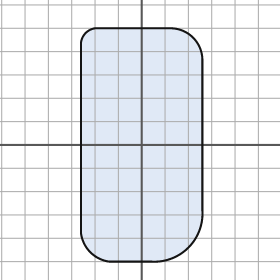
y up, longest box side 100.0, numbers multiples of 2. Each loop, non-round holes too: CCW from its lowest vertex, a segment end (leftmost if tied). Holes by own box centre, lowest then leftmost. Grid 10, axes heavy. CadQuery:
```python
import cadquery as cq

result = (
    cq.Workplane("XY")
    .moveTo(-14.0, -50.0)
    .lineTo(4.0, -50.0)
    .threePointArc((20.0, -44.0), (26.0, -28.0))
    .lineTo(26.0, 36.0)
    .threePointArc((22.0, 46.0), (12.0, 50.0))
    .lineTo(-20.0, 50.0)
    .threePointArc((-24.0, 48.0), (-26.0, 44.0))
    .lineTo(-26.0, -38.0)
    .threePointArc((-22.0, -46.0), (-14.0, -50.0))
    .close()
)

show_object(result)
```